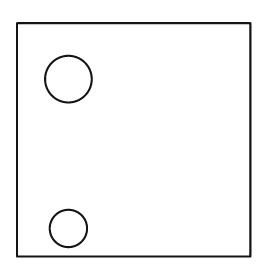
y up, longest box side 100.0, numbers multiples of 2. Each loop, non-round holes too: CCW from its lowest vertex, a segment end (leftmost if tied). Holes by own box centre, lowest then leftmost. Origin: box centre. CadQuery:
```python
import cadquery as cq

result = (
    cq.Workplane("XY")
    .moveTo(-50.0, -50.0)
    .lineTo(50.0, -50.0)
    .lineTo(50.0, 50.0)
    .lineTo(-50.0, 50.0)
    .close()
    .moveTo(-28.0, -38.0)
    .circle(8.0)
    .moveTo(-28.0, 26.0)
    .circle(10.0)
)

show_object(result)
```